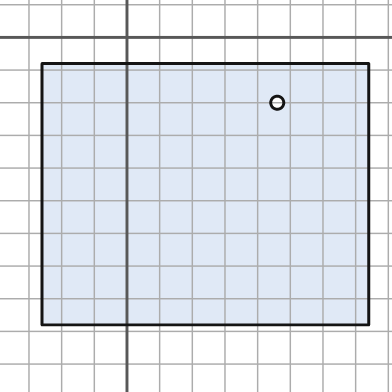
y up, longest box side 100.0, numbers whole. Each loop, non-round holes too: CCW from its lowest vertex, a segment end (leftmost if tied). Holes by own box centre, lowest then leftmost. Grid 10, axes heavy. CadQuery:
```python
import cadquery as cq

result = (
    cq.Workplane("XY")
    .moveTo(-26.0, -88.0)
    .lineTo(74.0, -88.0)
    .lineTo(74.0, -8.0)
    .lineTo(-26.0, -8.0)
    .close()
    .moveTo(46.0, -20.0)
    .circle(2.0)
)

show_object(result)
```